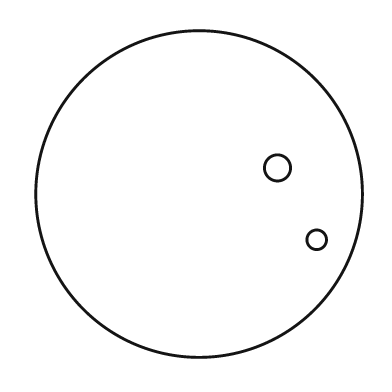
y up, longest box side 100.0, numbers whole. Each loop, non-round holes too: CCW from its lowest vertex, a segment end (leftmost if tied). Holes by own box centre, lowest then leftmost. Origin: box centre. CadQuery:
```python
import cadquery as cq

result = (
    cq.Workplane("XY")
    .moveTo(0.0, 0.0)
    .circle(50.0)
    .moveTo(36.0, -14.0)
    .circle(3.0)
    .moveTo(24.0, 8.0)
    .circle(4.0)
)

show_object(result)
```